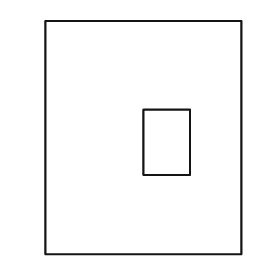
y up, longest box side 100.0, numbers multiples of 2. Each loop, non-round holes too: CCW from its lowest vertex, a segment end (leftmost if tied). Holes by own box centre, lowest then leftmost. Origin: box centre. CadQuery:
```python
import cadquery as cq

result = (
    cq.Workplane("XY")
    .moveTo(-42.0, -50.0)
    .lineTo(42.0, -50.0)
    .lineTo(42.0, 50.0)
    .lineTo(-42.0, 50.0)
    .close()
    .moveTo(0.0, -16.0)
    .lineTo(20.0, -16.0)
    .lineTo(20.0, 12.0)
    .lineTo(0.0, 12.0)
    .close()
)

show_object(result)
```